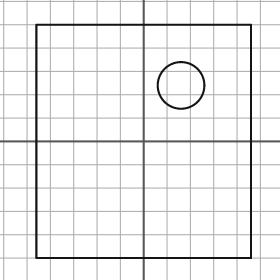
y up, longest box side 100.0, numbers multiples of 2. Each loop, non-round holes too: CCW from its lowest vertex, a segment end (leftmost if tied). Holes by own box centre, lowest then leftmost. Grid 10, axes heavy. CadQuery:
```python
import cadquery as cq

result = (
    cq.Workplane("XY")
    .moveTo(-46.0, -50.0)
    .lineTo(46.0, -50.0)
    .lineTo(46.0, 50.0)
    .lineTo(-46.0, 50.0)
    .close()
    .moveTo(16.0, 24.0)
    .circle(10.0)
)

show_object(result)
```